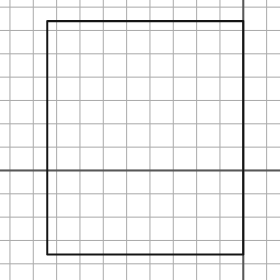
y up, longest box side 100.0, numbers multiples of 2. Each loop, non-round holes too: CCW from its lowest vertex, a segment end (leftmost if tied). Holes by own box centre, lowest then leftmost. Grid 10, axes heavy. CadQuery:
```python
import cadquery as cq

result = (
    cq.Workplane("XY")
    .moveTo(-84.0, -36.0)
    .lineTo(0.0, -36.0)
    .lineTo(0.0, 64.0)
    .lineTo(-84.0, 64.0)
    .close()
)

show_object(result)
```